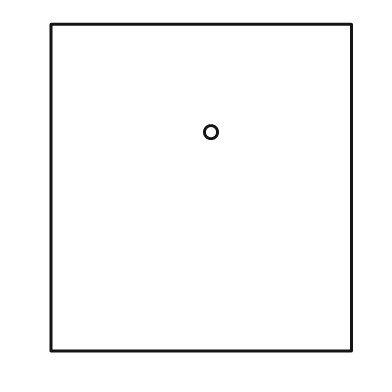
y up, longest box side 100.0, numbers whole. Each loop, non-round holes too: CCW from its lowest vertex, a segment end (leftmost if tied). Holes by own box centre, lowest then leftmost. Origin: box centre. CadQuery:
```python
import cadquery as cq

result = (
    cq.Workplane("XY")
    .moveTo(-46.0, -50.0)
    .lineTo(46.0, -50.0)
    .lineTo(46.0, 50.0)
    .lineTo(-46.0, 50.0)
    .close()
    .moveTo(3.0, 17.0)
    .circle(2.0)
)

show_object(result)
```